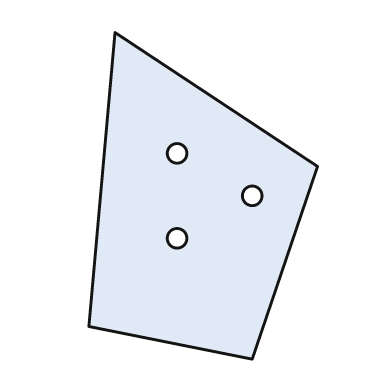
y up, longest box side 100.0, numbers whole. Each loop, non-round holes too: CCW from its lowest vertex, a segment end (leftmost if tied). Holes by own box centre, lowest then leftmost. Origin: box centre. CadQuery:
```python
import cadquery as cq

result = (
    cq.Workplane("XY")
    .moveTo(15.0, -50.0)
    .lineTo(35.0, 9.0)
    .lineTo(-27.0, 50.0)
    .lineTo(-35.0, -40.0)
    .close()
    .moveTo(-8.0, -13.0)
    .circle(3.0)
    .moveTo(15.0, 0.0)
    .circle(3.0)
    .moveTo(-8.0, 13.0)
    .circle(3.0)
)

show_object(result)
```